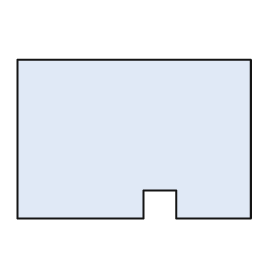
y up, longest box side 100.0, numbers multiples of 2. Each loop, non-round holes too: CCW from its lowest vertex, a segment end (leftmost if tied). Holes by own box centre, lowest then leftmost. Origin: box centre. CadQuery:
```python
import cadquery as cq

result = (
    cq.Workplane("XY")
    .moveTo(-50.0, -34.0)
    .lineTo(4.0, -34.0)
    .lineTo(4.0, -22.0)
    .lineTo(18.0, -22.0)
    .lineTo(18.0, -34.0)
    .lineTo(50.0, -34.0)
    .lineTo(50.0, 34.0)
    .lineTo(-50.0, 34.0)
    .close()
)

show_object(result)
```